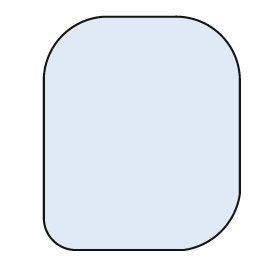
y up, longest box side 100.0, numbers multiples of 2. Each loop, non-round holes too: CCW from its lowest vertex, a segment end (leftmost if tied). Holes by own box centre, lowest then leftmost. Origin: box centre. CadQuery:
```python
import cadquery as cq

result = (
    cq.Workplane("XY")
    .moveTo(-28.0, -50.0)
    .lineTo(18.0, -50.0)
    .threePointArc((34.0, -42.0), (42.0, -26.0))
    .lineTo(42.0, 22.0)
    .threePointArc((34.0, 42.0), (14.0, 50.0))
    .lineTo(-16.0, 50.0)
    .threePointArc((-34.0, 42.0), (-42.0, 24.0))
    .lineTo(-42.0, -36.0)
    .threePointArc((-38.0, -46.0), (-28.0, -50.0))
    .close()
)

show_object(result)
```